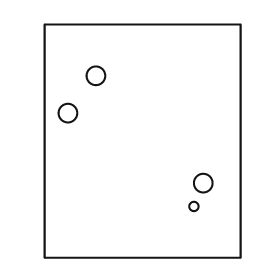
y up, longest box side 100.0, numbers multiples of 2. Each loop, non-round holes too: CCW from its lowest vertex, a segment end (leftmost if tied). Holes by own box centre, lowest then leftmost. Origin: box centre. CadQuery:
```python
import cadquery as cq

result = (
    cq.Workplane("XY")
    .moveTo(-42.0, -50.0)
    .lineTo(42.0, -50.0)
    .lineTo(42.0, 50.0)
    .lineTo(-42.0, 50.0)
    .close()
    .moveTo(22.0, -28.0)
    .circle(2.0)
    .moveTo(26.0, -18.0)
    .circle(4.0)
    .moveTo(-32.0, 12.0)
    .circle(4.0)
    .moveTo(-20.0, 28.0)
    .circle(4.0)
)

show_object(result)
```